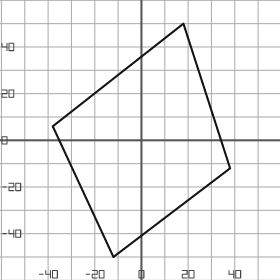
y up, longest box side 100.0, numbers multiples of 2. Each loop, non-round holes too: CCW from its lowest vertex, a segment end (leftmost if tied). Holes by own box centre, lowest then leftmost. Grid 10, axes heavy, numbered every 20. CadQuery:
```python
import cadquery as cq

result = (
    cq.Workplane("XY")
    .moveTo(-12.0, -50.0)
    .lineTo(38.0, -12.0)
    .lineTo(18.0, 50.0)
    .lineTo(-38.0, 6.0)
    .close()
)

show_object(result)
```